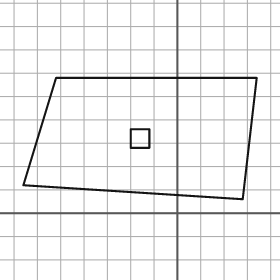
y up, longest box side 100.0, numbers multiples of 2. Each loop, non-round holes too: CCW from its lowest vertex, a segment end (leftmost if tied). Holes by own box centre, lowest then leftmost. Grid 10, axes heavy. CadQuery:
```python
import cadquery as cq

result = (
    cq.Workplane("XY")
    .moveTo(28.0, 6.0)
    .lineTo(34.0, 58.0)
    .lineTo(-52.0, 58.0)
    .lineTo(-66.0, 12.0)
    .close()
    .moveTo(-20.0, 28.0)
    .lineTo(-12.0, 28.0)
    .lineTo(-12.0, 36.0)
    .lineTo(-20.0, 36.0)
    .close()
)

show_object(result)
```